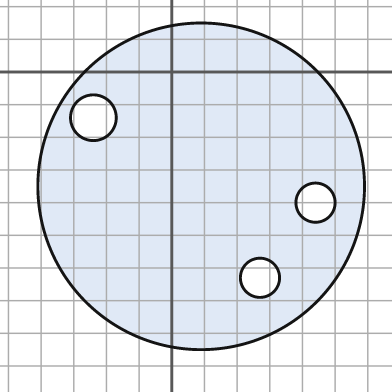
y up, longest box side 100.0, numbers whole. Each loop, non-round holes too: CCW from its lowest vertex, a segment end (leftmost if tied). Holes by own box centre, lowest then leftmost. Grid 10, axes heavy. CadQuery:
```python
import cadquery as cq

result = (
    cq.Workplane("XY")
    .moveTo(9.0, -35.0)
    .circle(50.0)
    .moveTo(27.0, -63.0)
    .circle(6.0)
    .moveTo(44.0, -40.0)
    .circle(6.0)
    .moveTo(-24.0, -14.0)
    .circle(7.0)
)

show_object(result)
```